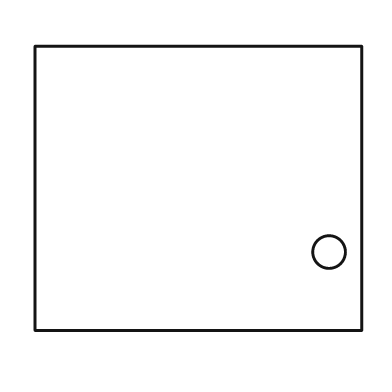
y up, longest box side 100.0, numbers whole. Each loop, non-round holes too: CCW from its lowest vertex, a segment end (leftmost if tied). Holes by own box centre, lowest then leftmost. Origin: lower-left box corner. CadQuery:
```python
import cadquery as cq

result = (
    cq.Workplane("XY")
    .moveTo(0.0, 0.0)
    .lineTo(100.0, 0.0)
    .lineTo(100.0, 87.0)
    .lineTo(0.0, 87.0)
    .close()
    .moveTo(90.0, 24.0)
    .circle(5.0)
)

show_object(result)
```